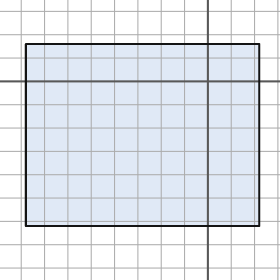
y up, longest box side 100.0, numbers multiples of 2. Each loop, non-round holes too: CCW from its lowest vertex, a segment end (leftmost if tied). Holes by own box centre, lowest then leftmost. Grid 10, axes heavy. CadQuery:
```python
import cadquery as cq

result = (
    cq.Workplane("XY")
    .moveTo(-78.0, -62.0)
    .lineTo(22.0, -62.0)
    .lineTo(22.0, 16.0)
    .lineTo(-78.0, 16.0)
    .close()
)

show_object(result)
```